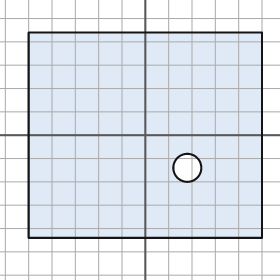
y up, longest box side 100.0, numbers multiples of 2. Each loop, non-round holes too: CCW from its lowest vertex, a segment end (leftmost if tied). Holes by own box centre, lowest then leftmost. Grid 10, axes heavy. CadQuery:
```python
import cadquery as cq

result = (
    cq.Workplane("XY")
    .moveTo(-50.0, -44.0)
    .lineTo(50.0, -44.0)
    .lineTo(50.0, 44.0)
    .lineTo(-50.0, 44.0)
    .close()
    .moveTo(18.0, -14.0)
    .circle(6.0)
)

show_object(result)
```